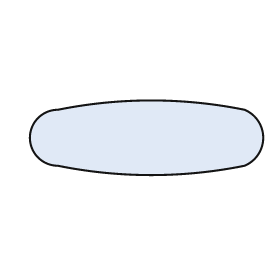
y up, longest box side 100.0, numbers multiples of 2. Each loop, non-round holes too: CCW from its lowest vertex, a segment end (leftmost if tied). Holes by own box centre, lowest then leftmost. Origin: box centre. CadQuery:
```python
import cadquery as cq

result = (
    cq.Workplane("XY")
    .moveTo(-38.0, -12.0)
    .threePointArc((2.0, -16.0), (42.0, -12.0))
    .threePointArc((50.0, 0.0), (42.0, 12.0))
    .threePointArc((2.0, 16.0), (-38.0, 12.0))
    .threePointArc((-50.0, 0.0), (-38.0, -12.0))
    .close()
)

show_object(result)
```